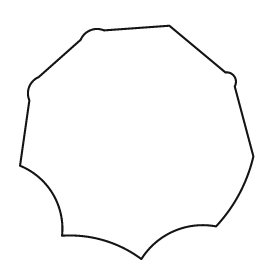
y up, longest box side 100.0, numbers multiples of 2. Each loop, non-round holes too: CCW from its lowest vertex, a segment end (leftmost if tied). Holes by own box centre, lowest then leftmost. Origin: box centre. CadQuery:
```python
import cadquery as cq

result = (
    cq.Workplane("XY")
    .moveTo(2.0, -50.0)
    .threePointArc((16.0, -38.0), (34.0, -36.0))
    .threePointArc((44.0, -22.0), (50.0, -6.0))
    .lineTo(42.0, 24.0)
    .threePointArc((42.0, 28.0), (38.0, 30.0))
    .lineTo(14.0, 50.0)
    .lineTo(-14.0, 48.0)
    .threePointArc((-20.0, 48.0), (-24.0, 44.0))
    .lineTo(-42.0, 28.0)
    .threePointArc((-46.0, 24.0), (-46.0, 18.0))
    .lineTo(-50.0, -10.0)
    .threePointArc((-36.0, -22.0), (-32.0, -40.0))
    .threePointArc((-14.0, -42.0), (2.0, -50.0))
    .close()
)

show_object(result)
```